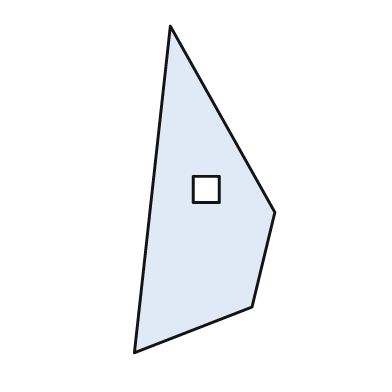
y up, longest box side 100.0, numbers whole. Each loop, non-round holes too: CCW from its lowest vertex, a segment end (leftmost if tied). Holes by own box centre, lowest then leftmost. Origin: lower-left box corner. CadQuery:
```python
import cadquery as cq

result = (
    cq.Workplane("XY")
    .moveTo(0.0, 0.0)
    .lineTo(36.0, 14.0)
    .lineTo(43.0, 43.0)
    .lineTo(11.0, 100.0)
    .close()
    .moveTo(18.0, 46.0)
    .lineTo(26.0, 46.0)
    .lineTo(26.0, 54.0)
    .lineTo(18.0, 54.0)
    .close()
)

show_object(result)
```